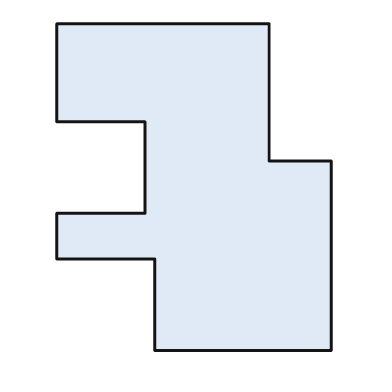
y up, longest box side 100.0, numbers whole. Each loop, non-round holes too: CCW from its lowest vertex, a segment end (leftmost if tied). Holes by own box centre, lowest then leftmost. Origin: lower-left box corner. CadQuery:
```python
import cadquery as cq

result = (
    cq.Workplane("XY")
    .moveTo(30.0, 0.0)
    .lineTo(84.0, 0.0)
    .lineTo(84.0, 58.0)
    .lineTo(65.0, 58.0)
    .lineTo(65.0, 100.0)
    .lineTo(0.0, 100.0)
    .lineTo(0.0, 70.0)
    .lineTo(27.0, 70.0)
    .lineTo(27.0, 42.0)
    .lineTo(0.0, 42.0)
    .lineTo(0.0, 28.0)
    .lineTo(30.0, 28.0)
    .close()
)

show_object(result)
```